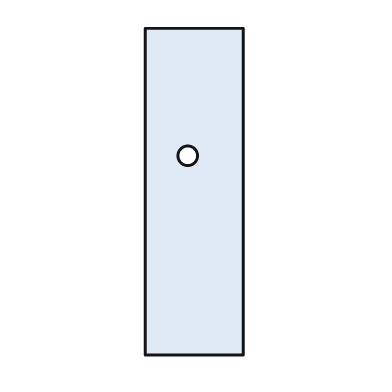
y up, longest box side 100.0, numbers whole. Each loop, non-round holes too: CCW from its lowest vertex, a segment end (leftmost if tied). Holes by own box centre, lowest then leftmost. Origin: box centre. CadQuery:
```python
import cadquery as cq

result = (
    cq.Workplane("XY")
    .moveTo(-15.0, -50.0)
    .lineTo(15.0, -50.0)
    .lineTo(15.0, 50.0)
    .lineTo(-15.0, 50.0)
    .close()
    .moveTo(-2.0, 11.0)
    .circle(3.0)
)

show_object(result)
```